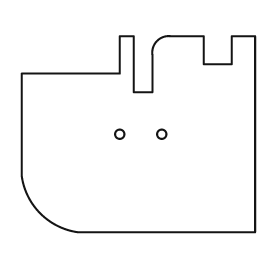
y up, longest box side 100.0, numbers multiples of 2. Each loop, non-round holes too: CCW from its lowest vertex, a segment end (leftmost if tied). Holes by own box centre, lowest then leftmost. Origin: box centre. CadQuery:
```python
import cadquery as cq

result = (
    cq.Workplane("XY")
    .moveTo(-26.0, -42.0)
    .lineTo(50.0, -42.0)
    .lineTo(50.0, 42.0)
    .lineTo(40.0, 42.0)
    .lineTo(40.0, 30.0)
    .lineTo(28.0, 30.0)
    .lineTo(28.0, 42.0)
    .lineTo(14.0, 42.0)
    .threePointArc((8.0, 40.0), (6.0, 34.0))
    .lineTo(6.0, 18.0)
    .lineTo(-2.0, 18.0)
    .lineTo(-2.0, 42.0)
    .lineTo(-8.0, 42.0)
    .lineTo(-8.0, 26.0)
    .lineTo(-50.0, 26.0)
    .lineTo(-50.0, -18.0)
    .threePointArc((-42.0, -34.0), (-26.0, -42.0))
    .close()
    .moveTo(-8.0, 0.0)
    .circle(2.0)
    .moveTo(10.0, 0.0)
    .circle(2.0)
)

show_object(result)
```